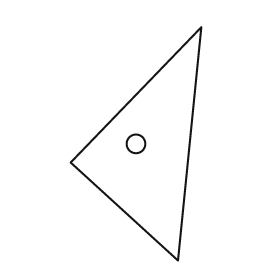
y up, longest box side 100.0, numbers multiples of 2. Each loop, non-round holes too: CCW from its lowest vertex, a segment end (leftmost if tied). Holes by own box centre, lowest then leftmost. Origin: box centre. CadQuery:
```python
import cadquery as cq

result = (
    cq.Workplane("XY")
    .moveTo(18.0, -50.0)
    .lineTo(28.0, 50.0)
    .lineTo(-28.0, -8.0)
    .close()
    .moveTo(0.0, 0.0)
    .circle(4.0)
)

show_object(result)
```